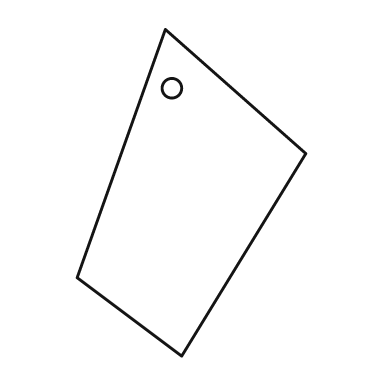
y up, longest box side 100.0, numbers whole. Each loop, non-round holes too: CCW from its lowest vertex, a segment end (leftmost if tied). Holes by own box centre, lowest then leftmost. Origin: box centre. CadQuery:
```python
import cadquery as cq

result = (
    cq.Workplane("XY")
    .moveTo(-3.0, -50.0)
    .lineTo(35.0, 12.0)
    .lineTo(-8.0, 50.0)
    .lineTo(-35.0, -26.0)
    .close()
    .moveTo(-6.0, 32.0)
    .circle(3.0)
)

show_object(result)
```